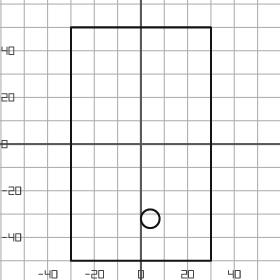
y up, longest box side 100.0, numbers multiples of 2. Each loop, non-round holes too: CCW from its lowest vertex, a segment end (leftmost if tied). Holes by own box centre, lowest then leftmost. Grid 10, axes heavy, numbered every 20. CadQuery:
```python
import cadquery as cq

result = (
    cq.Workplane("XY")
    .moveTo(-30.0, -50.0)
    .lineTo(30.0, -50.0)
    .lineTo(30.0, 50.0)
    .lineTo(-30.0, 50.0)
    .close()
    .moveTo(4.0, -32.0)
    .circle(4.0)
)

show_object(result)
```